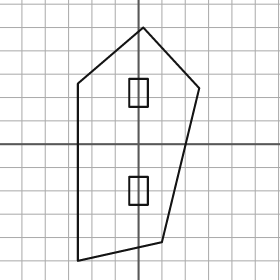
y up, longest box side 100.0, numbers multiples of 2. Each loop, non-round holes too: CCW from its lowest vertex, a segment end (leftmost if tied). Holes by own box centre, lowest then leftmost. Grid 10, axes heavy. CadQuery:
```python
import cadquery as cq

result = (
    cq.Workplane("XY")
    .moveTo(-26.0, -50.0)
    .lineTo(10.0, -42.0)
    .lineTo(26.0, 24.0)
    .lineTo(2.0, 50.0)
    .lineTo(-26.0, 26.0)
    .close()
    .moveTo(-4.0, -26.0)
    .lineTo(4.0, -26.0)
    .lineTo(4.0, -14.0)
    .lineTo(-4.0, -14.0)
    .close()
    .moveTo(-4.0, 16.0)
    .lineTo(4.0, 16.0)
    .lineTo(4.0, 28.0)
    .lineTo(-4.0, 28.0)
    .close()
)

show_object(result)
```